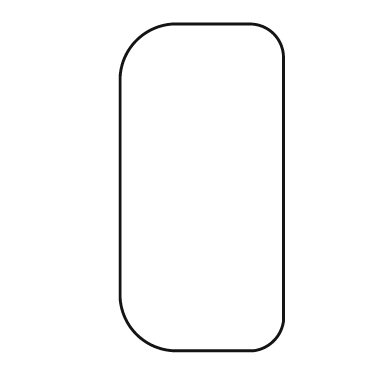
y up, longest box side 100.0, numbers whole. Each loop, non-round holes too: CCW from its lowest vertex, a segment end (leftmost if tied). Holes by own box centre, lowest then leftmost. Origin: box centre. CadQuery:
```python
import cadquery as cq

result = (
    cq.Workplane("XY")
    .moveTo(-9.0, -50.0)
    .lineTo(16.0, -50.0)
    .threePointArc((22.0, -47.0), (25.0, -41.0))
    .lineTo(25.0, 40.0)
    .threePointArc((22.0, 47.0), (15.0, 50.0))
    .lineTo(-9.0, 50.0)
    .threePointArc((-20.0, 45.0), (-25.0, 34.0))
    .lineTo(-25.0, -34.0)
    .threePointArc((-20.0, -45.0), (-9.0, -50.0))
    .close()
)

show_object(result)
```